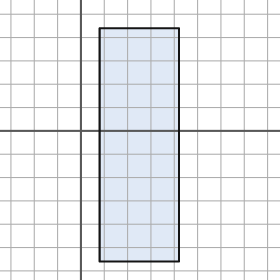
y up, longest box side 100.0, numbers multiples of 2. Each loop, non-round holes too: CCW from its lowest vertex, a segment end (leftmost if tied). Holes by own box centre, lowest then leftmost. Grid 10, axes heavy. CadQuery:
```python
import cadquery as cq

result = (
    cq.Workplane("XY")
    .moveTo(8.0, -56.0)
    .lineTo(42.0, -56.0)
    .lineTo(42.0, 44.0)
    .lineTo(8.0, 44.0)
    .close()
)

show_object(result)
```